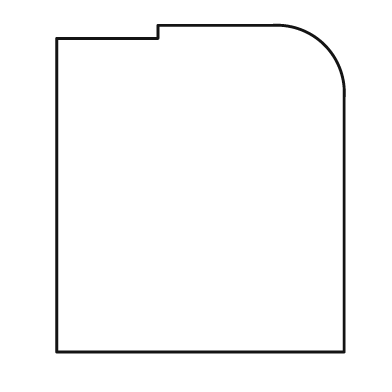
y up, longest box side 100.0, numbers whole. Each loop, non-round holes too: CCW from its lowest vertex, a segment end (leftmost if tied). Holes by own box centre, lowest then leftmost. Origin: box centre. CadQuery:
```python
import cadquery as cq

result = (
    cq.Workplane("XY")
    .moveTo(-44.0, -50.0)
    .lineTo(44.0, -50.0)
    .lineTo(44.0, 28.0)
    .threePointArc((38.0, 44.0), (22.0, 50.0))
    .lineTo(-13.0, 50.0)
    .lineTo(-13.0, 46.0)
    .lineTo(-44.0, 46.0)
    .close()
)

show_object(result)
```